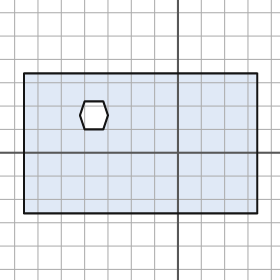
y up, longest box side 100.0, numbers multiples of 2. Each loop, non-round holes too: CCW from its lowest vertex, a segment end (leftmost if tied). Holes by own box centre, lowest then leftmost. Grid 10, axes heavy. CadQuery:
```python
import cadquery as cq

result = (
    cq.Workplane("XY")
    .moveTo(-66.0, -26.0)
    .lineTo(34.0, -26.0)
    .lineTo(34.0, 34.0)
    .lineTo(-66.0, 34.0)
    .close()
    .moveTo(-40.0, 10.0)
    .lineTo(-32.0, 10.0)
    .lineTo(-30.0, 16.0)
    .lineTo(-32.0, 22.0)
    .lineTo(-40.0, 22.0)
    .lineTo(-42.0, 16.0)
    .close()
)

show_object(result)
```